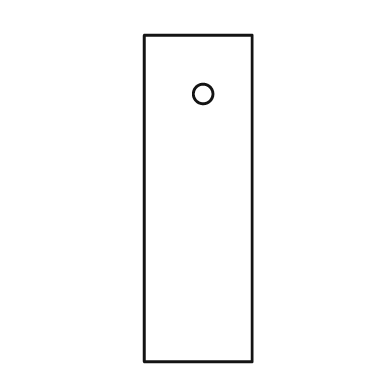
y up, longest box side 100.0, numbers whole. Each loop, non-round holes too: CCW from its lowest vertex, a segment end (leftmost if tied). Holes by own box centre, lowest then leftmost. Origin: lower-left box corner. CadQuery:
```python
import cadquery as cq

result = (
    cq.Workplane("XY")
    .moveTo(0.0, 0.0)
    .lineTo(33.0, 0.0)
    .lineTo(33.0, 100.0)
    .lineTo(0.0, 100.0)
    .close()
    .moveTo(18.0, 82.0)
    .circle(3.0)
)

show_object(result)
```